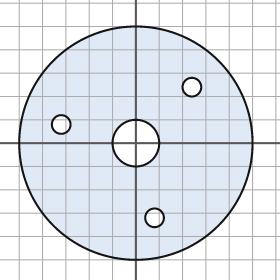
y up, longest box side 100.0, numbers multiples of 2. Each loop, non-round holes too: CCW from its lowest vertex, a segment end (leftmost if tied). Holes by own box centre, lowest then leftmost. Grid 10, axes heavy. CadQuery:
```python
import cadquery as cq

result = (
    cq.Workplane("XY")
    .moveTo(0.0, 0.0)
    .circle(50.0)
    .moveTo(8.0, -32.0)
    .circle(4.0)
    .moveTo(0.0, 0.0)
    .circle(10.0)
    .moveTo(-32.0, 8.0)
    .circle(4.0)
    .moveTo(24.0, 24.0)
    .circle(4.0)
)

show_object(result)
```